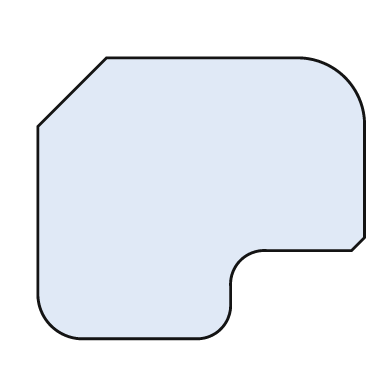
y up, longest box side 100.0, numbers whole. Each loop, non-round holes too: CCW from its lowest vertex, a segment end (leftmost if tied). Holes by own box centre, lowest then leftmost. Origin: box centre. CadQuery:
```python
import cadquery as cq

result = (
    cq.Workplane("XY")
    .moveTo(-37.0, -43.0)
    .lineTo(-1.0, -43.0)
    .threePointArc((6.0, -40.0), (9.0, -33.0))
    .lineTo(9.0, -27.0)
    .threePointArc((12.0, -19.0), (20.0, -16.0))
    .lineTo(46.0, -16.0)
    .lineTo(50.0, -12.0)
    .lineTo(50.0, 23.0)
    .threePointArc((44.0, 37.0), (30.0, 43.0))
    .lineTo(-29.0, 43.0)
    .lineTo(-50.0, 22.0)
    .lineTo(-50.0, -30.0)
    .threePointArc((-46.0, -39.0), (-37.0, -43.0))
    .close()
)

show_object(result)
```